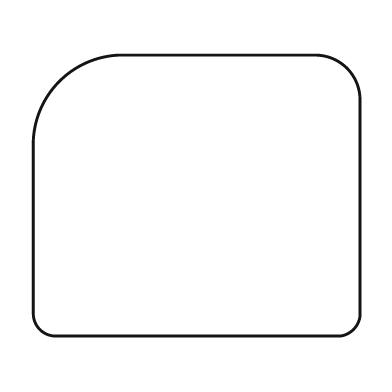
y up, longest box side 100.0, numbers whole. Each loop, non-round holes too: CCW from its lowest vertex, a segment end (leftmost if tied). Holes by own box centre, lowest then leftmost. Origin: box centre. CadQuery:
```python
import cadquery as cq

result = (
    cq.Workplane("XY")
    .moveTo(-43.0, -43.0)
    .lineTo(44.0, -43.0)
    .threePointArc((48.0, -41.0), (50.0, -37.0))
    .lineTo(50.0, 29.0)
    .threePointArc((46.0, 39.0), (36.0, 43.0))
    .lineTo(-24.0, 43.0)
    .threePointArc((-42.0, 35.0), (-50.0, 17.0))
    .lineTo(-50.0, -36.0)
    .threePointArc((-48.0, -41.0), (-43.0, -43.0))
    .close()
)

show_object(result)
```